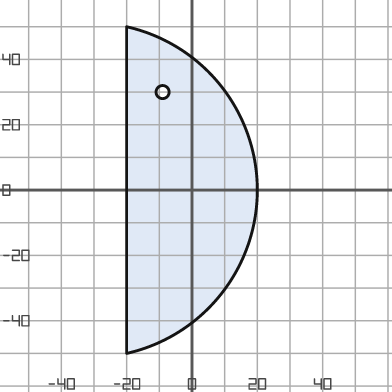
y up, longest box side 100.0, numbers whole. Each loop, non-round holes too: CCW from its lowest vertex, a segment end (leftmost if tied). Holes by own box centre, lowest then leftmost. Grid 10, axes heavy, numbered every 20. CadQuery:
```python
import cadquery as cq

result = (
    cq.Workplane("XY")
    .moveTo(-20.0, -50.0)
    .threePointArc((20.0, 0.0), (-20.0, 50.0))
    .close()
    .moveTo(-9.0, 30.0)
    .circle(2.0)
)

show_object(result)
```